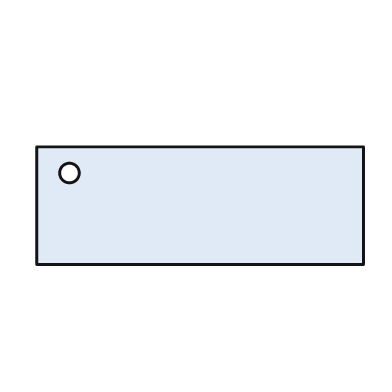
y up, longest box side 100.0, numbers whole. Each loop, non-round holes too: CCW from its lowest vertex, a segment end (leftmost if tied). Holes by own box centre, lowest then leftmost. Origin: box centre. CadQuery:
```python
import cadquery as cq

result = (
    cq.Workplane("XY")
    .moveTo(-50.0, -18.0)
    .lineTo(50.0, -18.0)
    .lineTo(50.0, 18.0)
    .lineTo(-50.0, 18.0)
    .close()
    .moveTo(-40.0, 10.0)
    .circle(3.0)
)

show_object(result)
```